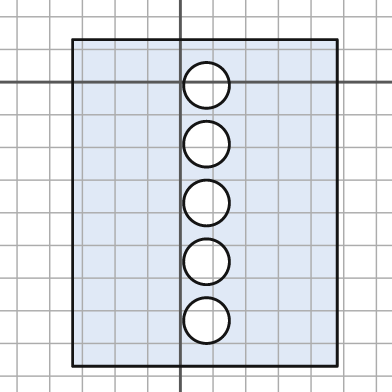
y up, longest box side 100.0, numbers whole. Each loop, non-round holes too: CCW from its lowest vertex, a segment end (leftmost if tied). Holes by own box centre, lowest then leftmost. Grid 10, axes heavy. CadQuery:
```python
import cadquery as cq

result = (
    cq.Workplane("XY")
    .moveTo(-33.0, -87.0)
    .lineTo(48.0, -87.0)
    .lineTo(48.0, 13.0)
    .lineTo(-33.0, 13.0)
    .close()
    .moveTo(8.0, -73.0)
    .circle(7.0)
    .moveTo(8.0, -55.0)
    .circle(7.0)
    .moveTo(8.0, -37.0)
    .circle(7.0)
    .moveTo(8.0, -19.0)
    .circle(7.0)
    .moveTo(8.0, -1.0)
    .circle(7.0)
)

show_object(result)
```